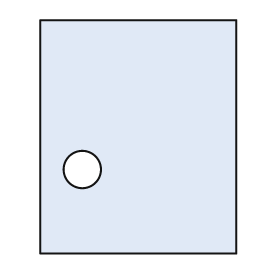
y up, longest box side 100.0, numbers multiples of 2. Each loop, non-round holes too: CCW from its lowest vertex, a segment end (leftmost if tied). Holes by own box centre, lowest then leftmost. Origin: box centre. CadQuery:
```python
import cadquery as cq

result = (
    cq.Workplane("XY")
    .moveTo(-42.0, -50.0)
    .lineTo(42.0, -50.0)
    .lineTo(42.0, 50.0)
    .lineTo(-42.0, 50.0)
    .close()
    .moveTo(-24.0, -14.0)
    .circle(8.0)
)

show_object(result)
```